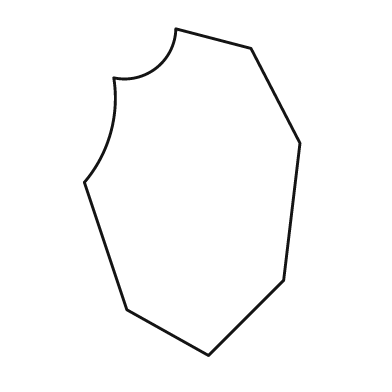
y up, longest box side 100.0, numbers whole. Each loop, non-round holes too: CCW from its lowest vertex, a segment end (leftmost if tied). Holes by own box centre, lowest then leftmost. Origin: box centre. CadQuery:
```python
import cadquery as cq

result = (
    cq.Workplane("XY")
    .moveTo(5.0, -50.0)
    .lineTo(28.0, -27.0)
    .lineTo(33.0, 15.0)
    .lineTo(18.0, 44.0)
    .lineTo(-5.0, 50.0)
    .threePointArc((-11.0, 38.0), (-24.0, 35.0))
    .threePointArc((-25.0, 18.0), (-33.0, 3.0))
    .lineTo(-20.0, -36.0)
    .close()
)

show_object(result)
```